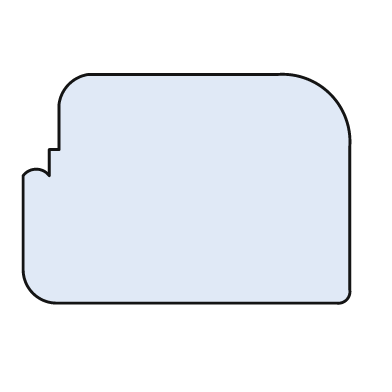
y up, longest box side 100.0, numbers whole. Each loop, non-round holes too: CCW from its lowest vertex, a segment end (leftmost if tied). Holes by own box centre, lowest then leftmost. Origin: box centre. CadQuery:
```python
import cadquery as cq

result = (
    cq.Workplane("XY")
    .moveTo(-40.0, -35.0)
    .lineTo(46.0, -35.0)
    .threePointArc((49.0, -34.0), (50.0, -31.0))
    .lineTo(50.0, 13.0)
    .threePointArc((44.0, 29.0), (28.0, 35.0))
    .lineTo(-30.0, 35.0)
    .threePointArc((-36.0, 32.0), (-39.0, 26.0))
    .lineTo(-39.0, 12.0)
    .lineTo(-42.0, 12.0)
    .lineTo(-42.0, 4.0)
    .threePointArc((-46.0, 6.0), (-50.0, 4.0))
    .lineTo(-50.0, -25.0)
    .threePointArc((-47.0, -32.0), (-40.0, -35.0))
    .close()
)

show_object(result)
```